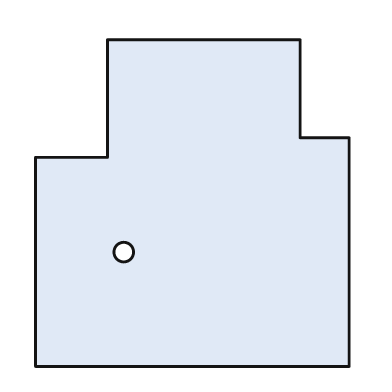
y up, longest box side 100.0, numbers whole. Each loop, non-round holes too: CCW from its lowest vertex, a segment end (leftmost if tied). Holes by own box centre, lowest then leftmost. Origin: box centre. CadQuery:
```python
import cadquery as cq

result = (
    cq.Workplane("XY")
    .moveTo(-48.0, -50.0)
    .lineTo(48.0, -50.0)
    .lineTo(48.0, 20.0)
    .lineTo(33.0, 20.0)
    .lineTo(33.0, 50.0)
    .lineTo(-26.0, 50.0)
    .lineTo(-26.0, 14.0)
    .lineTo(-48.0, 14.0)
    .close()
    .moveTo(-21.0, -15.0)
    .circle(3.0)
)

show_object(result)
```